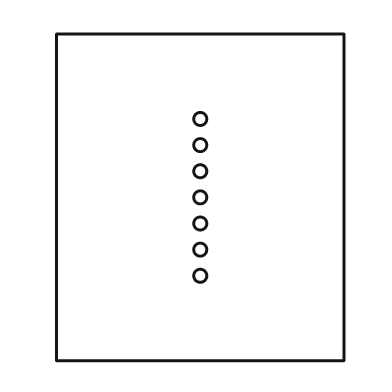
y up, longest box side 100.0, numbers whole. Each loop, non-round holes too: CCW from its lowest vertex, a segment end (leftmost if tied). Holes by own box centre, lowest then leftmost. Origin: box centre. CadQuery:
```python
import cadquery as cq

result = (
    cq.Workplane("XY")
    .moveTo(-44.0, -50.0)
    .lineTo(44.0, -50.0)
    .lineTo(44.0, 50.0)
    .lineTo(-44.0, 50.0)
    .close()
    .moveTo(0.0, -24.0)
    .circle(2.0)
    .moveTo(0.0, -16.0)
    .circle(2.0)
    .moveTo(0.0, -8.0)
    .circle(2.0)
    .moveTo(0.0, 0.0)
    .circle(2.0)
    .moveTo(0.0, 8.0)
    .circle(2.0)
    .moveTo(0.0, 16.0)
    .circle(2.0)
    .moveTo(0.0, 24.0)
    .circle(2.0)
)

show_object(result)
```